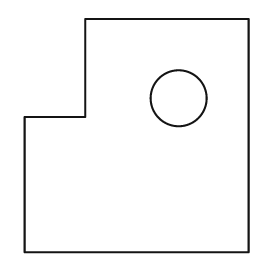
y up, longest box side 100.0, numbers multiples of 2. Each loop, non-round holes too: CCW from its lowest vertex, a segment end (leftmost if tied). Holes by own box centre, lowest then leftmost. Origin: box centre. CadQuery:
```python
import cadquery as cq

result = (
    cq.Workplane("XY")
    .moveTo(-48.0, -50.0)
    .lineTo(48.0, -50.0)
    .lineTo(48.0, 50.0)
    .lineTo(-22.0, 50.0)
    .lineTo(-22.0, 8.0)
    .lineTo(-48.0, 8.0)
    .close()
    .moveTo(18.0, 16.0)
    .circle(12.0)
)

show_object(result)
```